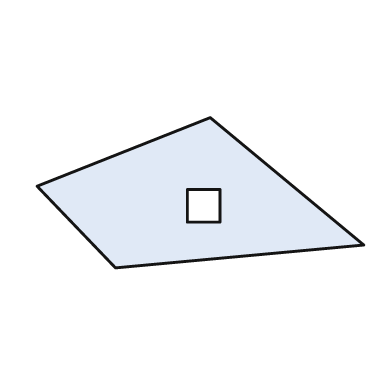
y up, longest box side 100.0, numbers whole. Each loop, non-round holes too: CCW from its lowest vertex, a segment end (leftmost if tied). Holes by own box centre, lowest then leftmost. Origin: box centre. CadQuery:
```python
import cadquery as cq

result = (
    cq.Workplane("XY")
    .moveTo(-26.0, -23.0)
    .lineTo(50.0, -16.0)
    .lineTo(3.0, 23.0)
    .lineTo(-50.0, 2.0)
    .close()
    .moveTo(-4.0, -9.0)
    .lineTo(6.0, -9.0)
    .lineTo(6.0, 1.0)
    .lineTo(-4.0, 1.0)
    .close()
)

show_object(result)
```